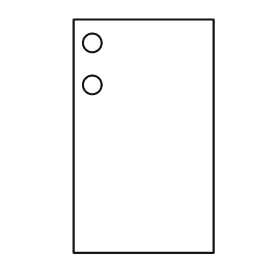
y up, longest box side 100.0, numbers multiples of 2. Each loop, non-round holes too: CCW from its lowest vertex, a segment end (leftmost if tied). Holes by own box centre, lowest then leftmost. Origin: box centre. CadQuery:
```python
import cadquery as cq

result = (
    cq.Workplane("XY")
    .moveTo(-30.0, -50.0)
    .lineTo(30.0, -50.0)
    .lineTo(30.0, 50.0)
    .lineTo(-30.0, 50.0)
    .close()
    .moveTo(-22.0, 22.0)
    .circle(4.0)
    .moveTo(-22.0, 40.0)
    .circle(4.0)
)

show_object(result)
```